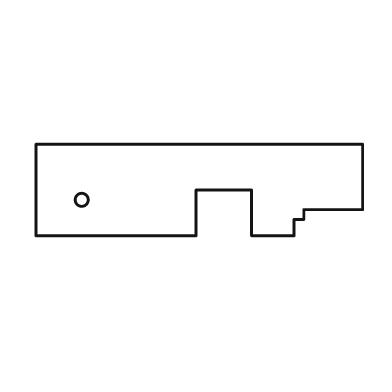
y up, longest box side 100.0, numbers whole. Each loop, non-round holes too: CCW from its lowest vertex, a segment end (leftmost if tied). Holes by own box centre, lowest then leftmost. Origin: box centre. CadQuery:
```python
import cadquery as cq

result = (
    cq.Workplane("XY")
    .moveTo(-50.0, -14.0)
    .lineTo(-1.0, -14.0)
    .lineTo(-1.0, 0.0)
    .lineTo(16.0, 0.0)
    .lineTo(16.0, -14.0)
    .lineTo(29.0, -14.0)
    .lineTo(29.0, -9.0)
    .lineTo(32.0, -9.0)
    .lineTo(32.0, -6.0)
    .lineTo(50.0, -6.0)
    .lineTo(50.0, 14.0)
    .lineTo(-50.0, 14.0)
    .close()
    .moveTo(-36.0, -3.0)
    .circle(2.0)
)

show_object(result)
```